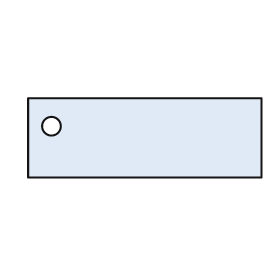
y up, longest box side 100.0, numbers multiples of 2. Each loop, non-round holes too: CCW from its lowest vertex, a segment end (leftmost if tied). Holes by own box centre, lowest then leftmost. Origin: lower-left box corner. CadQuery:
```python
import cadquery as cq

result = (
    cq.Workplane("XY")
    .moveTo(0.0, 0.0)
    .lineTo(100.0, 0.0)
    .lineTo(100.0, 34.0)
    .lineTo(0.0, 34.0)
    .close()
    .moveTo(10.0, 22.0)
    .circle(4.0)
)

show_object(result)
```